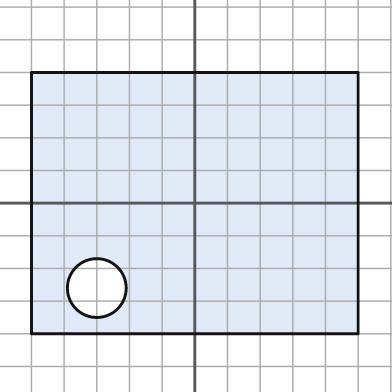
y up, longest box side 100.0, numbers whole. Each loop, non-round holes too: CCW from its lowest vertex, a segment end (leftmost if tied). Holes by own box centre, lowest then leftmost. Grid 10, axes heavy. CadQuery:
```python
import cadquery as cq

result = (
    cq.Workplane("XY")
    .moveTo(-50.0, -40.0)
    .lineTo(50.0, -40.0)
    .lineTo(50.0, 40.0)
    .lineTo(-50.0, 40.0)
    .close()
    .moveTo(-30.0, -26.0)
    .circle(9.0)
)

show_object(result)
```